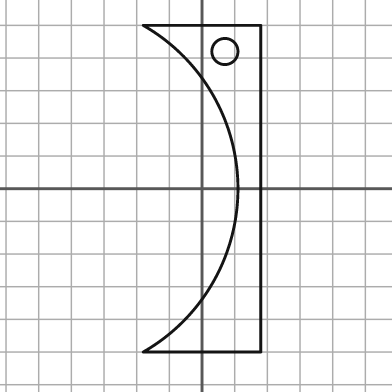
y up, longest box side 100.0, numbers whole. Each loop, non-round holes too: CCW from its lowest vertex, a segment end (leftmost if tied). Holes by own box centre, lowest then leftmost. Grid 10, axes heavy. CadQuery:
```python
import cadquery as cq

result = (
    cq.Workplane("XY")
    .moveTo(-18.0, -50.0)
    .lineTo(18.0, -50.0)
    .lineTo(18.0, 50.0)
    .lineTo(-18.0, 50.0)
    .threePointArc((11.0, 0.0), (-18.0, -50.0))
    .close()
    .moveTo(7.0, 42.0)
    .circle(4.0)
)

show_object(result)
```